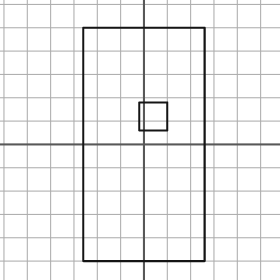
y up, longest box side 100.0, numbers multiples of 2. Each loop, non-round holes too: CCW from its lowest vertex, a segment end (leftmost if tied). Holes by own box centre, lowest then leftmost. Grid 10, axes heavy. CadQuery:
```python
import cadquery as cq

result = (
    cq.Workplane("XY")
    .moveTo(-26.0, -50.0)
    .lineTo(26.0, -50.0)
    .lineTo(26.0, 50.0)
    .lineTo(-26.0, 50.0)
    .close()
    .moveTo(-2.0, 6.0)
    .lineTo(10.0, 6.0)
    .lineTo(10.0, 18.0)
    .lineTo(-2.0, 18.0)
    .close()
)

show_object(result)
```